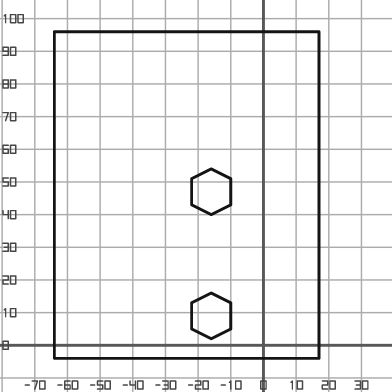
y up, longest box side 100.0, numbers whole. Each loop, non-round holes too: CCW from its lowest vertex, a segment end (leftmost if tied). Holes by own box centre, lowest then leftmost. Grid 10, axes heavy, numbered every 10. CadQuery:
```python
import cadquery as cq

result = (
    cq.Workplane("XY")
    .moveTo(-64.0, -4.0)
    .lineTo(17.0, -4.0)
    .lineTo(17.0, 96.0)
    .lineTo(-64.0, 96.0)
    .close()
    .moveTo(-16.0, 2.0)
    .lineTo(-10.0, 5.0)
    .lineTo(-10.0, 13.0)
    .lineTo(-16.0, 16.0)
    .lineTo(-22.0, 13.0)
    .lineTo(-22.0, 5.0)
    .close()
    .moveTo(-16.0, 40.0)
    .lineTo(-10.0, 43.0)
    .lineTo(-10.0, 51.0)
    .lineTo(-16.0, 54.0)
    .lineTo(-22.0, 51.0)
    .lineTo(-22.0, 43.0)
    .close()
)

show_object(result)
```